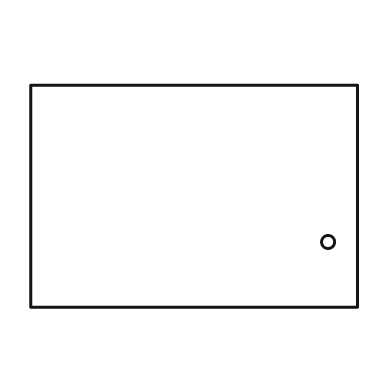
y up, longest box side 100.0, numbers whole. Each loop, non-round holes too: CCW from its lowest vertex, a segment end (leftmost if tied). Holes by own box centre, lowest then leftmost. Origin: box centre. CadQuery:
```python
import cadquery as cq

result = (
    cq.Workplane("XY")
    .moveTo(-50.0, -34.0)
    .lineTo(50.0, -34.0)
    .lineTo(50.0, 34.0)
    .lineTo(-50.0, 34.0)
    .close()
    .moveTo(41.0, -14.0)
    .circle(2.0)
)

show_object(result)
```